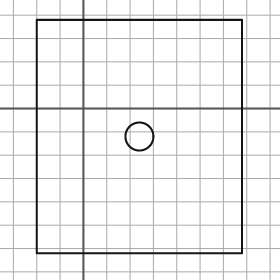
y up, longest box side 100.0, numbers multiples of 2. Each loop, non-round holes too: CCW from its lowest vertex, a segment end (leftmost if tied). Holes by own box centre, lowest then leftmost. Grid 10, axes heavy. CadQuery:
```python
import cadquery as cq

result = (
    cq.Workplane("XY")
    .moveTo(-20.0, -62.0)
    .lineTo(68.0, -62.0)
    .lineTo(68.0, 38.0)
    .lineTo(-20.0, 38.0)
    .close()
    .moveTo(24.0, -12.0)
    .circle(6.0)
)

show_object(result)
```